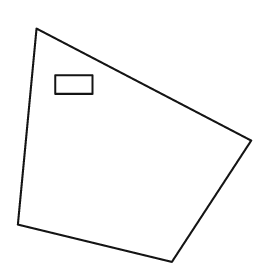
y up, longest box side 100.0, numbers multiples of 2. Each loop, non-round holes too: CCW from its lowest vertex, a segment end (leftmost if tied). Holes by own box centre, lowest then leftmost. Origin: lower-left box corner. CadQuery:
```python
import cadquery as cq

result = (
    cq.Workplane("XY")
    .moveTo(66.0, 0.0)
    .lineTo(100.0, 52.0)
    .lineTo(8.0, 100.0)
    .lineTo(0.0, 16.0)
    .close()
    .moveTo(16.0, 72.0)
    .lineTo(32.0, 72.0)
    .lineTo(32.0, 80.0)
    .lineTo(16.0, 80.0)
    .close()
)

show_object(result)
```